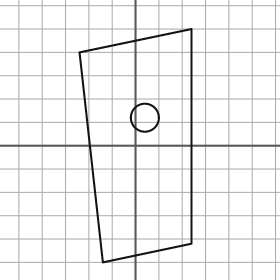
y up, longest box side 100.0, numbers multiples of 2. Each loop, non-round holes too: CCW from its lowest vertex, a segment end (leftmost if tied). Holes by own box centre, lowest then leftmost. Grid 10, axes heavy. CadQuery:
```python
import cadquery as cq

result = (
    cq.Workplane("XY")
    .moveTo(-14.0, -50.0)
    .lineTo(24.0, -42.0)
    .lineTo(24.0, 50.0)
    .lineTo(-24.0, 40.0)
    .close()
    .moveTo(4.0, 12.0)
    .circle(6.0)
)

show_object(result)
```